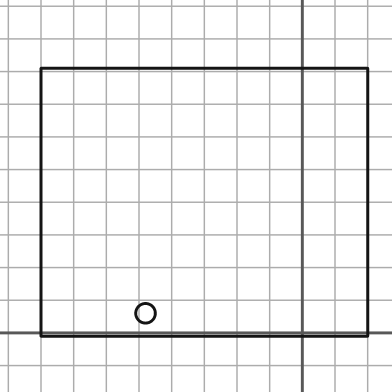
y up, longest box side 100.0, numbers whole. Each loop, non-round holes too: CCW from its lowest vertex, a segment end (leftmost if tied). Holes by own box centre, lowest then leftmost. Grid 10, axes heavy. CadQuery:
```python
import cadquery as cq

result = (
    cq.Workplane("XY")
    .moveTo(-80.0, -1.0)
    .lineTo(20.0, -1.0)
    .lineTo(20.0, 81.0)
    .lineTo(-80.0, 81.0)
    .close()
    .moveTo(-48.0, 6.0)
    .circle(3.0)
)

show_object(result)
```